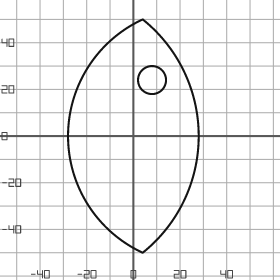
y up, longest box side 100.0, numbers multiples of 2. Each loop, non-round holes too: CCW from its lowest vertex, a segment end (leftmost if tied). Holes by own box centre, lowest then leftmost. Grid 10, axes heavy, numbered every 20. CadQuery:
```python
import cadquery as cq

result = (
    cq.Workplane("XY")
    .moveTo(4.0, -50.0)
    .threePointArc((28.0, 0.0), (4.0, 50.0))
    .threePointArc((-28.0, 0.0), (4.0, -50.0))
    .close()
    .moveTo(8.0, 24.0)
    .circle(6.0)
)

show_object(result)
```